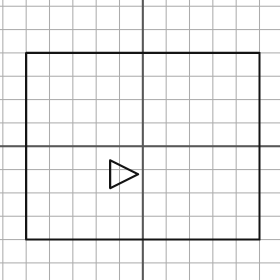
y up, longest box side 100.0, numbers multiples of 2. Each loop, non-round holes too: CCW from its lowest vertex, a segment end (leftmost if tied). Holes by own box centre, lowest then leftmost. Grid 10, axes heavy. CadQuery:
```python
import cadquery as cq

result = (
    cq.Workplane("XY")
    .moveTo(-50.0, -40.0)
    .lineTo(50.0, -40.0)
    .lineTo(50.0, 40.0)
    .lineTo(-50.0, 40.0)
    .close()
    .moveTo(-14.0, -18.0)
    .lineTo(-2.0, -12.0)
    .lineTo(-14.0, -6.0)
    .close()
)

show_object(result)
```